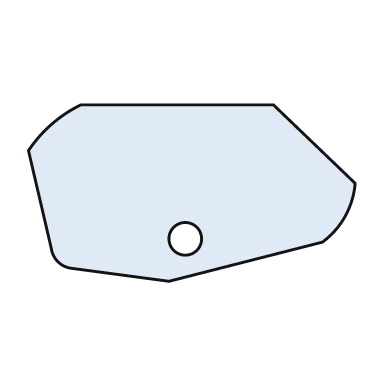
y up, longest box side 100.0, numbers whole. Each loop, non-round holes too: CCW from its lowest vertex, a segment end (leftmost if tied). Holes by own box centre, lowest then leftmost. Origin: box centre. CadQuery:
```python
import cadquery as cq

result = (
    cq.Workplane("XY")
    .moveTo(-7.0, -27.0)
    .lineTo(40.0, -15.0)
    .threePointArc((47.0, -7.0), (50.0, 3.0))
    .lineTo(25.0, 27.0)
    .lineTo(-34.0, 27.0)
    .threePointArc((-43.0, 21.0), (-50.0, 13.0))
    .lineTo(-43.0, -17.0)
    .threePointArc((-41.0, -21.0), (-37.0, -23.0))
    .close()
    .moveTo(-2.0, -14.0)
    .circle(5.0)
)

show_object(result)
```